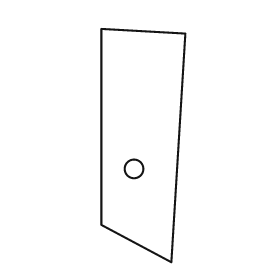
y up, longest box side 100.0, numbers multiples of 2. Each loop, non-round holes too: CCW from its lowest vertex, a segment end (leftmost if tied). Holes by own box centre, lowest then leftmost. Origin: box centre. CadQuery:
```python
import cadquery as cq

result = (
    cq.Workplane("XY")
    .moveTo(12.0, -50.0)
    .lineTo(18.0, 48.0)
    .lineTo(-18.0, 50.0)
    .lineTo(-18.0, -34.0)
    .close()
    .moveTo(-4.0, -10.0)
    .circle(4.0)
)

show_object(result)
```